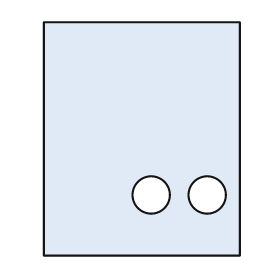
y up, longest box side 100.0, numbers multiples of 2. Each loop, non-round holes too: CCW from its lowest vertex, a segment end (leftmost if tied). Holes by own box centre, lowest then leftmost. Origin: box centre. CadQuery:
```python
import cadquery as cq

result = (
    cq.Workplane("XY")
    .moveTo(-42.0, -50.0)
    .lineTo(42.0, -50.0)
    .lineTo(42.0, 50.0)
    .lineTo(-42.0, 50.0)
    .close()
    .moveTo(4.0, -24.0)
    .circle(8.0)
    .moveTo(28.0, -24.0)
    .circle(8.0)
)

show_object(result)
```